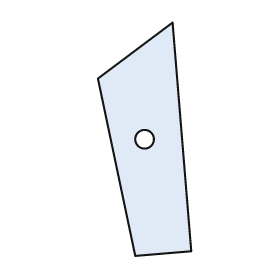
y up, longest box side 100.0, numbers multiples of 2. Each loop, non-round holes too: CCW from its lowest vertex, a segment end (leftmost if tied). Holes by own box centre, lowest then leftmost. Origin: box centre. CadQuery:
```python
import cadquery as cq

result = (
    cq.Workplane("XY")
    .moveTo(-4.0, -50.0)
    .lineTo(20.0, -48.0)
    .lineTo(12.0, 50.0)
    .lineTo(-20.0, 26.0)
    .close()
    .moveTo(0.0, 0.0)
    .circle(4.0)
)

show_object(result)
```